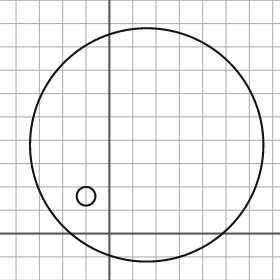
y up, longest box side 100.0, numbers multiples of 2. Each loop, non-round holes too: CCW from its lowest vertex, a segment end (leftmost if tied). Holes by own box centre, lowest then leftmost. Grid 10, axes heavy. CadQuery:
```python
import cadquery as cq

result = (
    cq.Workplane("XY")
    .moveTo(16.0, 38.0)
    .circle(50.0)
    .moveTo(-10.0, 16.0)
    .circle(4.0)
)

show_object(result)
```